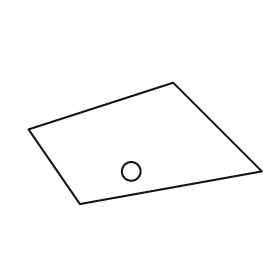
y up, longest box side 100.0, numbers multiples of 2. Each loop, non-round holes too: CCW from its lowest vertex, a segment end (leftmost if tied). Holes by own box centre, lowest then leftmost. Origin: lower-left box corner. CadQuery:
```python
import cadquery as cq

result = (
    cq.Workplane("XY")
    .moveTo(22.0, 0.0)
    .lineTo(100.0, 14.0)
    .lineTo(62.0, 52.0)
    .lineTo(0.0, 32.0)
    .close()
    .moveTo(44.0, 14.0)
    .circle(4.0)
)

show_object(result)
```